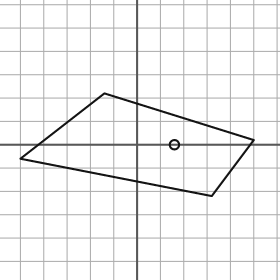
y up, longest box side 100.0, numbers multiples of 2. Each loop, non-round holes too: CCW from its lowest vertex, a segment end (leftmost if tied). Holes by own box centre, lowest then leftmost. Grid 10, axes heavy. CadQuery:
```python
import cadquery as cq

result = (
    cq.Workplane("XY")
    .moveTo(32.0, -22.0)
    .lineTo(50.0, 2.0)
    .lineTo(-14.0, 22.0)
    .lineTo(-50.0, -6.0)
    .close()
    .moveTo(16.0, 0.0)
    .circle(2.0)
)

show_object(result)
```